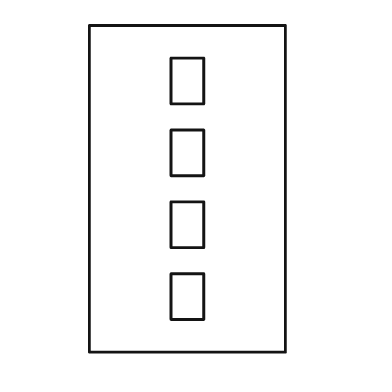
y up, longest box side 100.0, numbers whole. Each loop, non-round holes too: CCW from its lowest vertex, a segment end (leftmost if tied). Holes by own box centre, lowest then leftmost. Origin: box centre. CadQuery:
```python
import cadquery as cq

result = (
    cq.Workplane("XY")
    .moveTo(-30.0, -50.0)
    .lineTo(30.0, -50.0)
    .lineTo(30.0, 50.0)
    .lineTo(-30.0, 50.0)
    .close()
    .moveTo(-5.0, -40.0)
    .lineTo(5.0, -40.0)
    .lineTo(5.0, -26.0)
    .lineTo(-5.0, -26.0)
    .close()
    .moveTo(-5.0, -18.0)
    .lineTo(5.0, -18.0)
    .lineTo(5.0, -4.0)
    .lineTo(-5.0, -4.0)
    .close()
    .moveTo(-5.0, 4.0)
    .lineTo(5.0, 4.0)
    .lineTo(5.0, 18.0)
    .lineTo(-5.0, 18.0)
    .close()
    .moveTo(-5.0, 26.0)
    .lineTo(5.0, 26.0)
    .lineTo(5.0, 40.0)
    .lineTo(-5.0, 40.0)
    .close()
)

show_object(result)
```